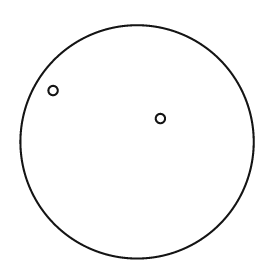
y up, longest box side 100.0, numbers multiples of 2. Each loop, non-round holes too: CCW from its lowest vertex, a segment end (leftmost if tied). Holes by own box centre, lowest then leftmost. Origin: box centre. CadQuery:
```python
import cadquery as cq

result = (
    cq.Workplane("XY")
    .moveTo(0.0, 0.0)
    .circle(50.0)
    .moveTo(10.0, 10.0)
    .circle(2.0)
    .moveTo(-36.0, 22.0)
    .circle(2.0)
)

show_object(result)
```